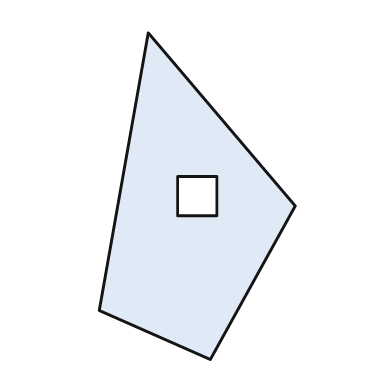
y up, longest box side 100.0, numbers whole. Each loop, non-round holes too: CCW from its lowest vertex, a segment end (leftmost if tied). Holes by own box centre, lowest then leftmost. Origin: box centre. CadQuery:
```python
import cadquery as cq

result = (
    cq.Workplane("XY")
    .moveTo(4.0, -50.0)
    .lineTo(30.0, -3.0)
    .lineTo(-15.0, 50.0)
    .lineTo(-30.0, -35.0)
    .close()
    .moveTo(-6.0, -6.0)
    .lineTo(6.0, -6.0)
    .lineTo(6.0, 6.0)
    .lineTo(-6.0, 6.0)
    .close()
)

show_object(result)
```